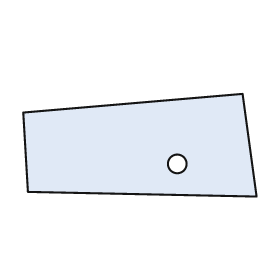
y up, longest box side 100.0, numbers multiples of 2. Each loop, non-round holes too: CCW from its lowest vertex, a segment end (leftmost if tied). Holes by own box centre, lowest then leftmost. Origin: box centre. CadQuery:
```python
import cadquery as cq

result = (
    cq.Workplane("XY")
    .moveTo(50.0, -22.0)
    .lineTo(44.0, 22.0)
    .lineTo(-50.0, 14.0)
    .lineTo(-48.0, -20.0)
    .close()
    .moveTo(16.0, -8.0)
    .circle(4.0)
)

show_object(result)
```